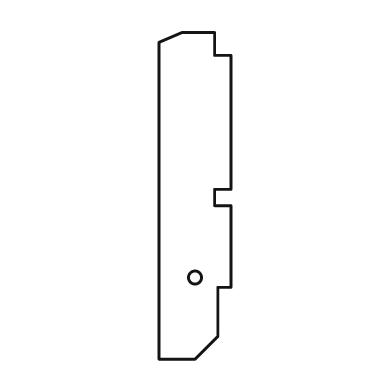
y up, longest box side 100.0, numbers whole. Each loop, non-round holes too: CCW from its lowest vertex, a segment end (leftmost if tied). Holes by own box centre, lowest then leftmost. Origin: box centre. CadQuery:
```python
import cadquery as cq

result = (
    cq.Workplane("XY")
    .moveTo(-11.0, -50.0)
    .lineTo(0.0, -50.0)
    .lineTo(7.0, -43.0)
    .lineTo(7.0, -28.0)
    .lineTo(11.0, -28.0)
    .lineTo(11.0, -3.0)
    .lineTo(6.0, -3.0)
    .lineTo(6.0, 2.0)
    .lineTo(11.0, 2.0)
    .lineTo(11.0, 43.0)
    .lineTo(6.0, 43.0)
    .lineTo(6.0, 50.0)
    .lineTo(-4.0, 50.0)
    .lineTo(-11.0, 47.0)
    .close()
    .moveTo(0.0, -25.0)
    .circle(2.0)
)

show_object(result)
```